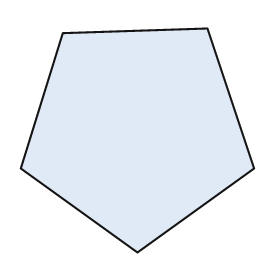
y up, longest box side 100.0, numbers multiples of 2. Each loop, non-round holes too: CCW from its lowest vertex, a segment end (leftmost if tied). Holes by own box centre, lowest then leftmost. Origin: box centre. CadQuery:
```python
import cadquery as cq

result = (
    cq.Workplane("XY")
    .moveTo(0.0, -48.0)
    .lineTo(50.0, -12.0)
    .lineTo(30.0, 48.0)
    .lineTo(-32.0, 46.0)
    .lineTo(-50.0, -12.0)
    .close()
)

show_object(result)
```